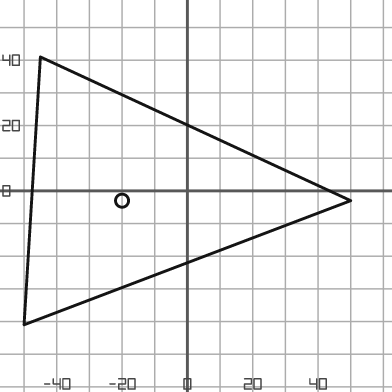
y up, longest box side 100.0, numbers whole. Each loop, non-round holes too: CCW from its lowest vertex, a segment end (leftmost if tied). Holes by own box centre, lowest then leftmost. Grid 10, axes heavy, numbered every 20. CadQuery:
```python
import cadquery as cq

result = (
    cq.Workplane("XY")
    .moveTo(-50.0, -41.0)
    .lineTo(50.0, -3.0)
    .lineTo(-45.0, 41.0)
    .close()
    .moveTo(-20.0, -3.0)
    .circle(2.0)
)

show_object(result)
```